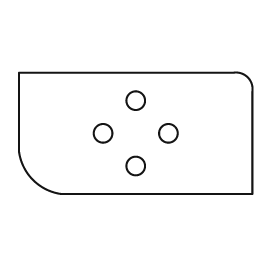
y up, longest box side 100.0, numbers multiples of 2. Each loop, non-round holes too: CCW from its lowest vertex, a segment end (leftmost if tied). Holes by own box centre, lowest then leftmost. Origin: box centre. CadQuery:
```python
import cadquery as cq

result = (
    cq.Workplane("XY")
    .moveTo(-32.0, -26.0)
    .lineTo(50.0, -26.0)
    .lineTo(50.0, 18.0)
    .threePointArc((48.0, 24.0), (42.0, 26.0))
    .lineTo(-50.0, 26.0)
    .lineTo(-50.0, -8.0)
    .threePointArc((-44.0, -20.0), (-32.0, -26.0))
    .close()
    .moveTo(0.0, -14.0)
    .circle(4.0)
    .moveTo(-14.0, 0.0)
    .circle(4.0)
    .moveTo(14.0, 0.0)
    .circle(4.0)
    .moveTo(0.0, 14.0)
    .circle(4.0)
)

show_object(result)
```